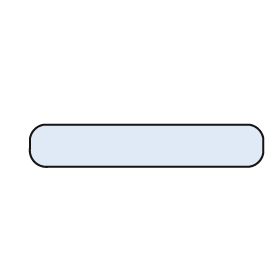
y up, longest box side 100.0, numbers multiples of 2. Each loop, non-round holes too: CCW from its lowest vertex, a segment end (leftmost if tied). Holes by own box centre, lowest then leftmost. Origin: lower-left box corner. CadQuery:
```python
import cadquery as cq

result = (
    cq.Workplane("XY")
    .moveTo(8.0, 0.0)
    .lineTo(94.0, 0.0)
    .threePointArc((98.0, 2.0), (100.0, 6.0))
    .lineTo(100.0, 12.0)
    .threePointArc((98.0, 16.0), (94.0, 18.0))
    .lineTo(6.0, 18.0)
    .threePointArc((2.0, 16.0), (0.0, 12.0))
    .lineTo(0.0, 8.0)
    .threePointArc((2.0, 2.0), (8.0, 0.0))
    .close()
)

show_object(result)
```